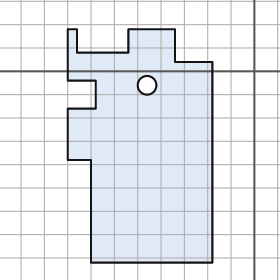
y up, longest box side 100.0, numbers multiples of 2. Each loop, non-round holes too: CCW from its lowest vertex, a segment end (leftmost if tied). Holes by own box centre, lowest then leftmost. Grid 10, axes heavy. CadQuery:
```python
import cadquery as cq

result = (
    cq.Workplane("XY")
    .moveTo(-70.0, -82.0)
    .lineTo(-18.0, -82.0)
    .lineTo(-18.0, 4.0)
    .lineTo(-34.0, 4.0)
    .lineTo(-34.0, 18.0)
    .lineTo(-54.0, 18.0)
    .lineTo(-54.0, 8.0)
    .lineTo(-76.0, 8.0)
    .lineTo(-76.0, 18.0)
    .lineTo(-80.0, 18.0)
    .lineTo(-80.0, -4.0)
    .lineTo(-68.0, -4.0)
    .lineTo(-68.0, -16.0)
    .lineTo(-80.0, -16.0)
    .lineTo(-80.0, -38.0)
    .lineTo(-70.0, -38.0)
    .close()
    .moveTo(-46.0, -6.0)
    .circle(4.0)
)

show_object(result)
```